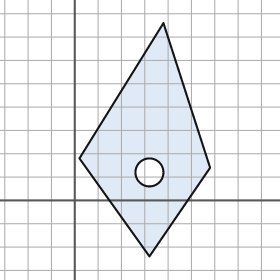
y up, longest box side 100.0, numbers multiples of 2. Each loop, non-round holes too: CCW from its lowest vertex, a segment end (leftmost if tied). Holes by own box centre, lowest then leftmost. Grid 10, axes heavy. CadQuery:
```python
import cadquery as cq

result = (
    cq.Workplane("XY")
    .moveTo(32.0, -24.0)
    .lineTo(58.0, 14.0)
    .lineTo(38.0, 76.0)
    .lineTo(2.0, 18.0)
    .close()
    .moveTo(32.0, 12.0)
    .circle(6.0)
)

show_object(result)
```